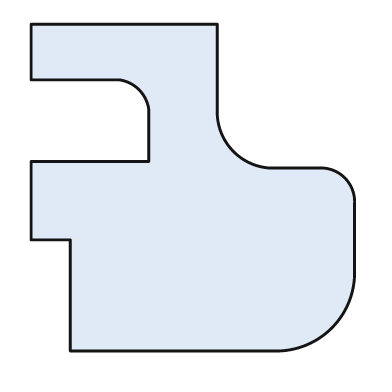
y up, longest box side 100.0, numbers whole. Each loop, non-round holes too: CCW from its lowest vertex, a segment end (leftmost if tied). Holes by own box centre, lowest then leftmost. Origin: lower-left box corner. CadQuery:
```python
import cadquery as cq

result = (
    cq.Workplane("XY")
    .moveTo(12.0, 0.0)
    .lineTo(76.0, 0.0)
    .threePointArc((92.0, 7.0), (99.0, 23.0))
    .lineTo(99.0, 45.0)
    .threePointArc((96.0, 53.0), (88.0, 56.0))
    .lineTo(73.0, 56.0)
    .threePointArc((62.0, 61.0), (57.0, 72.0))
    .lineTo(57.0, 100.0)
    .lineTo(0.0, 100.0)
    .lineTo(0.0, 83.0)
    .lineTo(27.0, 83.0)
    .threePointArc((33.0, 80.0), (36.0, 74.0))
    .lineTo(36.0, 58.0)
    .lineTo(0.0, 58.0)
    .lineTo(0.0, 34.0)
    .lineTo(12.0, 34.0)
    .close()
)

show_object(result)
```